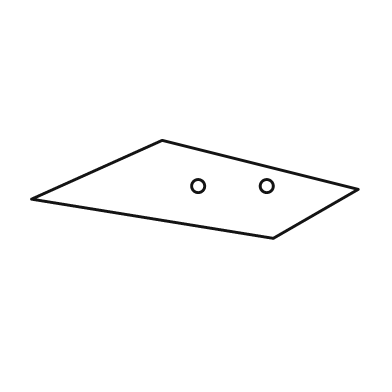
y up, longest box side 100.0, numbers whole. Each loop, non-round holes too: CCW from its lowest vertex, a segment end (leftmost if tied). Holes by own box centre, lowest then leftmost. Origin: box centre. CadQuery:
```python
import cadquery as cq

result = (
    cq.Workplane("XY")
    .moveTo(24.0, -15.0)
    .lineTo(50.0, 0.0)
    .lineTo(-10.0, 15.0)
    .lineTo(-50.0, -3.0)
    .close()
    .moveTo(1.0, 1.0)
    .circle(2.0)
    .moveTo(22.0, 1.0)
    .circle(2.0)
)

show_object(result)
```